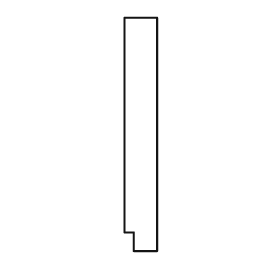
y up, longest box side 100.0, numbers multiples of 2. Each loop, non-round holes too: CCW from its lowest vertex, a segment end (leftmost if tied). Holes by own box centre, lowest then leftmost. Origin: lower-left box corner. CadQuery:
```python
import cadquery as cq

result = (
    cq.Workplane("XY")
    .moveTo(4.0, 0.0)
    .lineTo(14.0, 0.0)
    .lineTo(14.0, 100.0)
    .lineTo(0.0, 100.0)
    .lineTo(0.0, 8.0)
    .lineTo(4.0, 8.0)
    .close()
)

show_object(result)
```